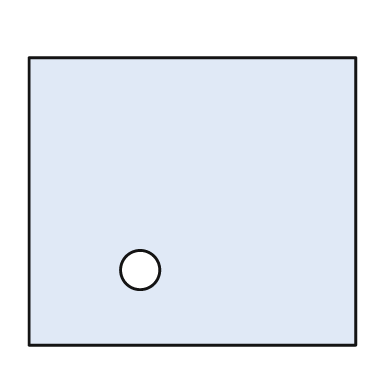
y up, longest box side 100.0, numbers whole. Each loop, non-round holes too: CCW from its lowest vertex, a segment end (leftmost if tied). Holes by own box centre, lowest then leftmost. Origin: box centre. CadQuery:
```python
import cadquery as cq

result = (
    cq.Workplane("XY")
    .moveTo(-50.0, -44.0)
    .lineTo(50.0, -44.0)
    .lineTo(50.0, 44.0)
    .lineTo(-50.0, 44.0)
    .close()
    .moveTo(-16.0, -21.0)
    .circle(6.0)
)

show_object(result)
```